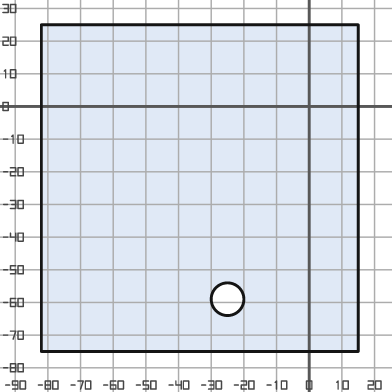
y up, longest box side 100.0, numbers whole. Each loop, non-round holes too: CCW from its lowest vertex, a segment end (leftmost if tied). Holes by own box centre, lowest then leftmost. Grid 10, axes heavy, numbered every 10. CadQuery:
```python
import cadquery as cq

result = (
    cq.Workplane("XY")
    .moveTo(-82.0, -75.0)
    .lineTo(15.0, -75.0)
    .lineTo(15.0, 25.0)
    .lineTo(-82.0, 25.0)
    .close()
    .moveTo(-25.0, -59.0)
    .circle(5.0)
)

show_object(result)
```